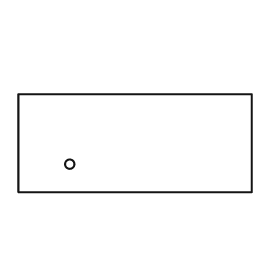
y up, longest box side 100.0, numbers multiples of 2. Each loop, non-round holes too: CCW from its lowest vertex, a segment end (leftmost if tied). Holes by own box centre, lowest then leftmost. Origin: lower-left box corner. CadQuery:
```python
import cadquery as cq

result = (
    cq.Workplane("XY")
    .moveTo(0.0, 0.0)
    .lineTo(100.0, 0.0)
    .lineTo(100.0, 42.0)
    .lineTo(0.0, 42.0)
    .close()
    .moveTo(22.0, 12.0)
    .circle(2.0)
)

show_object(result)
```